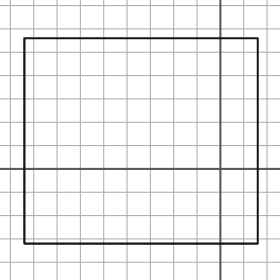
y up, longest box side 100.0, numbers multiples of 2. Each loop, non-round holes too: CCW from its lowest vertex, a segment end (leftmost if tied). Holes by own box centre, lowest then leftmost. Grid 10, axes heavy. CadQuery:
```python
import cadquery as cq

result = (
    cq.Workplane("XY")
    .moveTo(-84.0, -32.0)
    .lineTo(16.0, -32.0)
    .lineTo(16.0, 56.0)
    .lineTo(-84.0, 56.0)
    .close()
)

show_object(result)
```